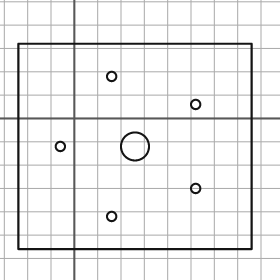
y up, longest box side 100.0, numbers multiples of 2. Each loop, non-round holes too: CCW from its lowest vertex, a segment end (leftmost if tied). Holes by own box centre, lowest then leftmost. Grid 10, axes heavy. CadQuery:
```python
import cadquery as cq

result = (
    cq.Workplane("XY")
    .moveTo(-24.0, -56.0)
    .lineTo(76.0, -56.0)
    .lineTo(76.0, 32.0)
    .lineTo(-24.0, 32.0)
    .close()
    .moveTo(16.0, -42.0)
    .circle(2.0)
    .moveTo(52.0, -30.0)
    .circle(2.0)
    .moveTo(-6.0, -12.0)
    .circle(2.0)
    .moveTo(26.0, -12.0)
    .circle(6.0)
    .moveTo(52.0, 6.0)
    .circle(2.0)
    .moveTo(16.0, 18.0)
    .circle(2.0)
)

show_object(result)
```